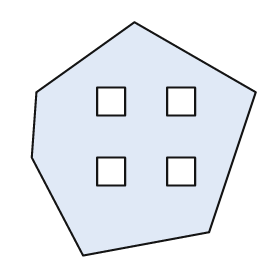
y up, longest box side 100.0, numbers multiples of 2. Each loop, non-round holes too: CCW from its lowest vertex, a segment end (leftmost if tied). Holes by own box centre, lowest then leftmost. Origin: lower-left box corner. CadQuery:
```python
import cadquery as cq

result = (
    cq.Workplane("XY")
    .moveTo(22.0, 0.0)
    .lineTo(76.0, 10.0)
    .lineTo(96.0, 70.0)
    .lineTo(44.0, 100.0)
    .lineTo(2.0, 70.0)
    .lineTo(0.0, 42.0)
    .close()
    .moveTo(28.0, 30.0)
    .lineTo(40.0, 30.0)
    .lineTo(40.0, 42.0)
    .lineTo(28.0, 42.0)
    .close()
    .moveTo(58.0, 30.0)
    .lineTo(70.0, 30.0)
    .lineTo(70.0, 42.0)
    .lineTo(58.0, 42.0)
    .close()
    .moveTo(28.0, 60.0)
    .lineTo(40.0, 60.0)
    .lineTo(40.0, 72.0)
    .lineTo(28.0, 72.0)
    .close()
    .moveTo(58.0, 60.0)
    .lineTo(70.0, 60.0)
    .lineTo(70.0, 72.0)
    .lineTo(58.0, 72.0)
    .close()
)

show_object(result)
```